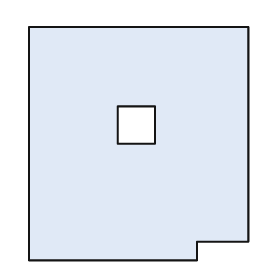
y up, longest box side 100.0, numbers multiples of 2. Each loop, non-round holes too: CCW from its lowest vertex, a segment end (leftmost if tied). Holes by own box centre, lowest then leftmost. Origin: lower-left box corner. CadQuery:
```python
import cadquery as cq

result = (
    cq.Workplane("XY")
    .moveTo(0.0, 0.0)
    .lineTo(72.0, 0.0)
    .lineTo(72.0, 8.0)
    .lineTo(94.0, 8.0)
    .lineTo(94.0, 100.0)
    .lineTo(0.0, 100.0)
    .close()
    .moveTo(38.0, 50.0)
    .lineTo(54.0, 50.0)
    .lineTo(54.0, 66.0)
    .lineTo(38.0, 66.0)
    .close()
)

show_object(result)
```